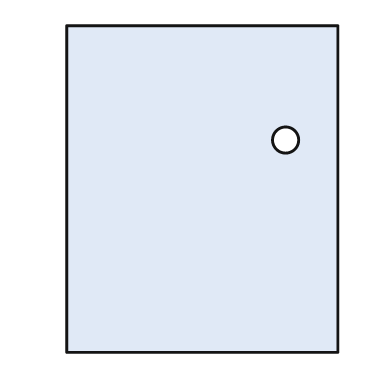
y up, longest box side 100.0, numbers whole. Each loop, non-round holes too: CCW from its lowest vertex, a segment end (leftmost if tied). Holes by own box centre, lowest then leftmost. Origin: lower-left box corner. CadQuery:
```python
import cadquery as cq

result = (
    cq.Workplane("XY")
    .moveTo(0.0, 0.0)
    .lineTo(83.0, 0.0)
    .lineTo(83.0, 100.0)
    .lineTo(0.0, 100.0)
    .close()
    .moveTo(67.0, 65.0)
    .circle(4.0)
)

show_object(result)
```